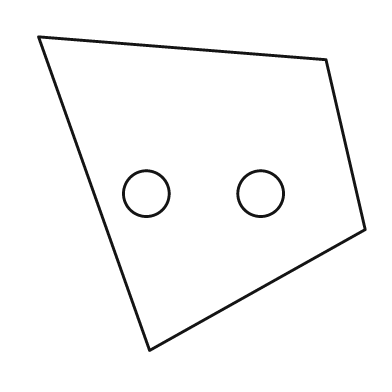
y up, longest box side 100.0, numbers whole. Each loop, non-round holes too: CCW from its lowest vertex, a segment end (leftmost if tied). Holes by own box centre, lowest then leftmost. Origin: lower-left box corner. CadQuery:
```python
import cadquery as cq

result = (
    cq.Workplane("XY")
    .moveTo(34.0, 0.0)
    .lineTo(100.0, 37.0)
    .lineTo(88.0, 89.0)
    .lineTo(0.0, 96.0)
    .close()
    .moveTo(33.0, 48.0)
    .circle(7.0)
    .moveTo(68.0, 48.0)
    .circle(7.0)
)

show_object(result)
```